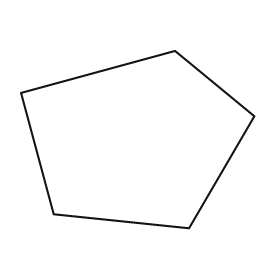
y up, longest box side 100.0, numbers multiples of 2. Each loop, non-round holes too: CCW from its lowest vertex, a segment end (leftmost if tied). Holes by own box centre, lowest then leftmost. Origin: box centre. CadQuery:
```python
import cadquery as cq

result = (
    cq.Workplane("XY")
    .moveTo(22.0, -38.0)
    .lineTo(50.0, 10.0)
    .lineTo(16.0, 38.0)
    .lineTo(-50.0, 20.0)
    .lineTo(-36.0, -32.0)
    .close()
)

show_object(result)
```